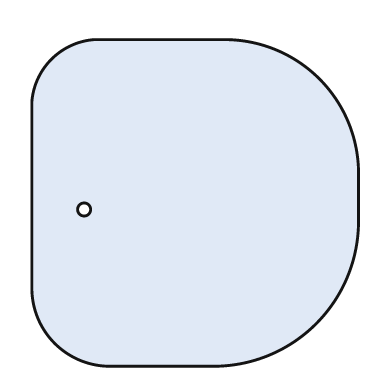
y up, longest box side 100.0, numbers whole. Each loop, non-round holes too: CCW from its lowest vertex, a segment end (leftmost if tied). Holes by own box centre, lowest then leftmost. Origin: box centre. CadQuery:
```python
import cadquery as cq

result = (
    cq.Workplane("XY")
    .moveTo(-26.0, -50.0)
    .lineTo(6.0, -50.0)
    .threePointArc((37.0, -37.0), (50.0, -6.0))
    .lineTo(50.0, 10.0)
    .threePointArc((38.0, 38.0), (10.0, 50.0))
    .lineTo(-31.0, 50.0)
    .threePointArc((-44.0, 44.0), (-50.0, 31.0))
    .lineTo(-50.0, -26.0)
    .threePointArc((-43.0, -43.0), (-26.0, -50.0))
    .close()
    .moveTo(-34.0, -2.0)
    .circle(2.0)
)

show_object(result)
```